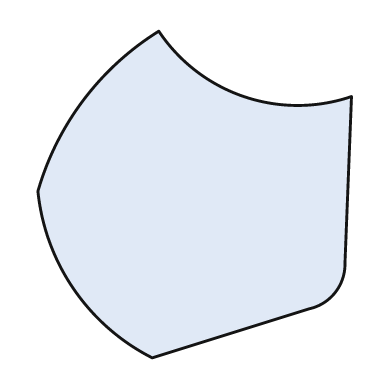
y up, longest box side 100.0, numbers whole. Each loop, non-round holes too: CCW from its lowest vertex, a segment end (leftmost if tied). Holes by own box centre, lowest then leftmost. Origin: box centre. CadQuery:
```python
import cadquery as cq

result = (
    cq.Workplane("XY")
    .moveTo(-13.0, -50.0)
    .lineTo(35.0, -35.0)
    .threePointArc((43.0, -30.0), (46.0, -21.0))
    .lineTo(48.0, 30.0)
    .threePointArc((15.0, 30.0), (-11.0, 50.0))
    .threePointArc((-34.0, 29.0), (-48.0, 1.0))
    .threePointArc((-37.0, -29.0), (-13.0, -50.0))
    .close()
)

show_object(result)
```